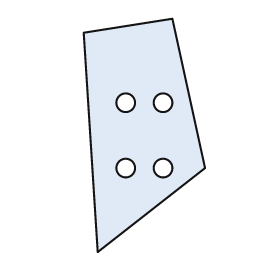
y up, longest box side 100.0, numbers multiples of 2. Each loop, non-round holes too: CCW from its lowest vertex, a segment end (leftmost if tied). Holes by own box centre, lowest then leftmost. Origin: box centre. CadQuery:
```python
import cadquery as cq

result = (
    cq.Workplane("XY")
    .moveTo(-20.0, -50.0)
    .lineTo(26.0, -14.0)
    .lineTo(12.0, 50.0)
    .lineTo(-26.0, 44.0)
    .close()
    .moveTo(-8.0, -14.0)
    .circle(4.0)
    .moveTo(8.0, -14.0)
    .circle(4.0)
    .moveTo(-8.0, 14.0)
    .circle(4.0)
    .moveTo(8.0, 14.0)
    .circle(4.0)
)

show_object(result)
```